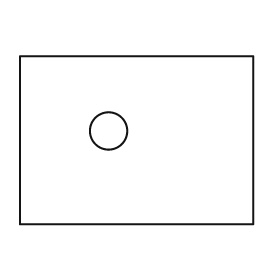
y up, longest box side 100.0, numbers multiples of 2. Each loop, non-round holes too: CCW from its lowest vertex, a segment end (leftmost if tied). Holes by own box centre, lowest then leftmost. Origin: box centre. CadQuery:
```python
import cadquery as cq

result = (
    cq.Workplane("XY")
    .moveTo(-50.0, -36.0)
    .lineTo(50.0, -36.0)
    .lineTo(50.0, 36.0)
    .lineTo(-50.0, 36.0)
    .close()
    .moveTo(-12.0, 4.0)
    .circle(8.0)
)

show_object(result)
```